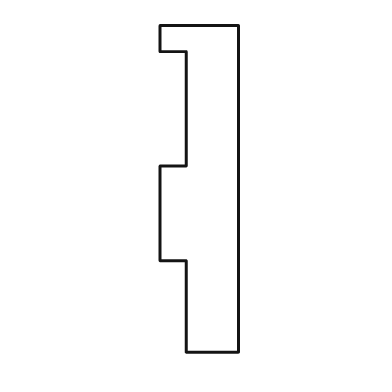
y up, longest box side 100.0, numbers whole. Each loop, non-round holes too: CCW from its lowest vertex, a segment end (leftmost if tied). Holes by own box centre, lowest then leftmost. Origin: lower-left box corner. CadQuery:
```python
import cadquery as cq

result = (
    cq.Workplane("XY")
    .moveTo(8.0, 0.0)
    .lineTo(24.0, 0.0)
    .lineTo(24.0, 100.0)
    .lineTo(0.0, 100.0)
    .lineTo(0.0, 92.0)
    .lineTo(8.0, 92.0)
    .lineTo(8.0, 57.0)
    .lineTo(0.0, 57.0)
    .lineTo(0.0, 28.0)
    .lineTo(8.0, 28.0)
    .close()
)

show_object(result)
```